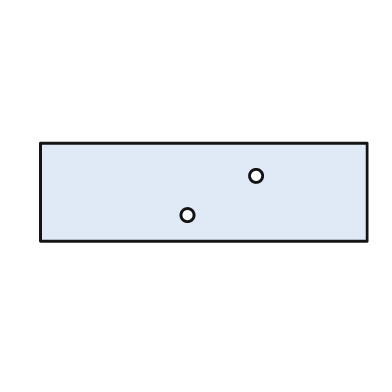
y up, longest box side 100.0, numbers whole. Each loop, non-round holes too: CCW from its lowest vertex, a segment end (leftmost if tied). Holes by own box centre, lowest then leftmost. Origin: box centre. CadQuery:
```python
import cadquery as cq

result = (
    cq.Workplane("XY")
    .moveTo(-50.0, -15.0)
    .lineTo(50.0, -15.0)
    .lineTo(50.0, 15.0)
    .lineTo(-50.0, 15.0)
    .close()
    .moveTo(-5.0, -7.0)
    .circle(2.0)
    .moveTo(16.0, 5.0)
    .circle(2.0)
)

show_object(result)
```